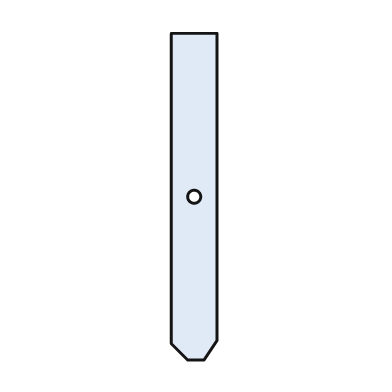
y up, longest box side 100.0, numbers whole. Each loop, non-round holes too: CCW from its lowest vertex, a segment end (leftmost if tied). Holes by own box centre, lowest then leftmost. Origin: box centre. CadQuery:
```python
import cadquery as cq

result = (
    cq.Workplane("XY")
    .moveTo(-2.0, -50.0)
    .lineTo(3.0, -50.0)
    .lineTo(7.0, -44.0)
    .lineTo(7.0, 50.0)
    .lineTo(-7.0, 50.0)
    .lineTo(-7.0, -45.0)
    .close()
    .moveTo(0.0, 0.0)
    .circle(2.0)
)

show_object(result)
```